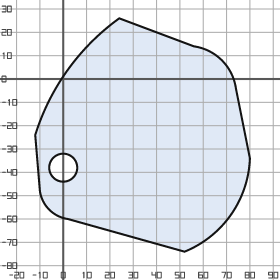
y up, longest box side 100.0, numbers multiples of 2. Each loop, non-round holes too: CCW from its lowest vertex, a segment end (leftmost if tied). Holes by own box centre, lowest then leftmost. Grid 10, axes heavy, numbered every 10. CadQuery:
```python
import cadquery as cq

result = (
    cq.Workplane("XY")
    .moveTo(52.0, -74.0)
    .threePointArc((72.0, -58.0), (80.0, -34.0))
    .lineTo(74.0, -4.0)
    .threePointArc((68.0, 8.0), (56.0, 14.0))
    .lineTo(24.0, 26.0)
    .threePointArc((2.0, 4.0), (-12.0, -24.0))
    .lineTo(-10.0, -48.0)
    .threePointArc((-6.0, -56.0), (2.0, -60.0))
    .close()
    .moveTo(0.0, -38.0)
    .circle(6.0)
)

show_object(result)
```